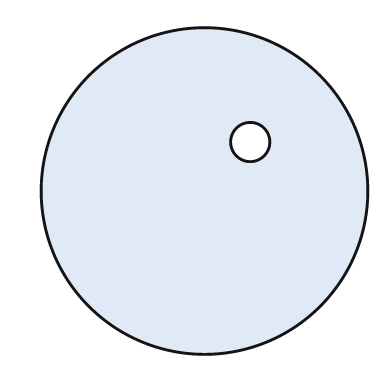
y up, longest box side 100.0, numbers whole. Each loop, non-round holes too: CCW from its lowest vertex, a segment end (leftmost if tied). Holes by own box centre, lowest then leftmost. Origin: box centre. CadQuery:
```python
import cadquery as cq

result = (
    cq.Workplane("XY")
    .moveTo(0.0, 0.0)
    .circle(50.0)
    .moveTo(14.0, 15.0)
    .circle(6.0)
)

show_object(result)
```